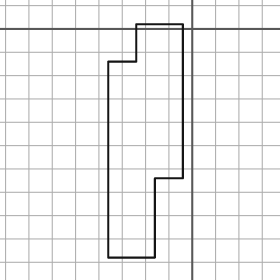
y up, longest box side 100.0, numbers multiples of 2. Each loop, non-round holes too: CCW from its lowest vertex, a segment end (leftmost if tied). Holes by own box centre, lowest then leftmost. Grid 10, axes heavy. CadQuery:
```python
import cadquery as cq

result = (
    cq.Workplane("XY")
    .moveTo(-36.0, -98.0)
    .lineTo(-16.0, -98.0)
    .lineTo(-16.0, -64.0)
    .lineTo(-4.0, -64.0)
    .lineTo(-4.0, 2.0)
    .lineTo(-24.0, 2.0)
    .lineTo(-24.0, -14.0)
    .lineTo(-36.0, -14.0)
    .close()
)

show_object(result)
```